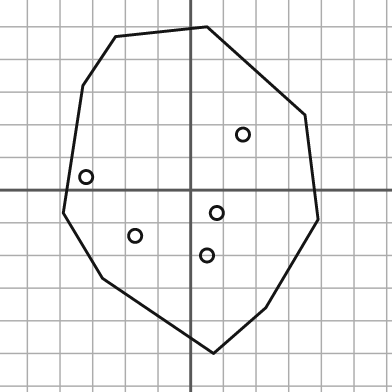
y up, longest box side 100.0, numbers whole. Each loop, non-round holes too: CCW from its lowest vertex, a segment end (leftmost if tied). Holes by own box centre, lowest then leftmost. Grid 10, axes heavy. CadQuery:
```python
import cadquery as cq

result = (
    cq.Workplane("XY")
    .moveTo(7.0, -50.0)
    .lineTo(23.0, -36.0)
    .lineTo(39.0, -9.0)
    .lineTo(35.0, 23.0)
    .lineTo(5.0, 50.0)
    .lineTo(-23.0, 47.0)
    .lineTo(-33.0, 32.0)
    .lineTo(-39.0, -7.0)
    .lineTo(-27.0, -27.0)
    .close()
    .moveTo(5.0, -20.0)
    .circle(2.0)
    .moveTo(-17.0, -14.0)
    .circle(2.0)
    .moveTo(8.0, -7.0)
    .circle(2.0)
    .moveTo(-32.0, 4.0)
    .circle(2.0)
    .moveTo(16.0, 17.0)
    .circle(2.0)
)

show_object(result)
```